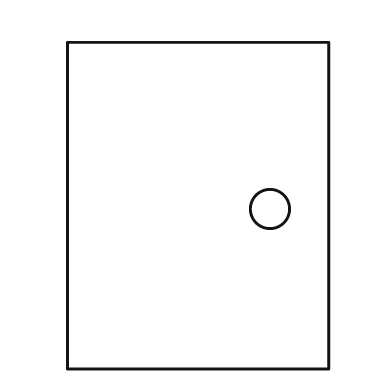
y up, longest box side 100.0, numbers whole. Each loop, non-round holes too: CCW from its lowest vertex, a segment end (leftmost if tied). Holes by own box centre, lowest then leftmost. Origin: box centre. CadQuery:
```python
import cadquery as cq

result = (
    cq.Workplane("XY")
    .moveTo(-40.0, -50.0)
    .lineTo(40.0, -50.0)
    .lineTo(40.0, 50.0)
    .lineTo(-40.0, 50.0)
    .close()
    .moveTo(22.0, -1.0)
    .circle(6.0)
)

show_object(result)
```